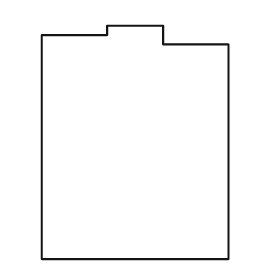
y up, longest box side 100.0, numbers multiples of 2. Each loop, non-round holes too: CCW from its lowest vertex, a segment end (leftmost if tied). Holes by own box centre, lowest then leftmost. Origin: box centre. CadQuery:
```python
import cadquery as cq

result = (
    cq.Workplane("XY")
    .moveTo(-40.0, -50.0)
    .lineTo(40.0, -50.0)
    .lineTo(40.0, 42.0)
    .lineTo(12.0, 42.0)
    .lineTo(12.0, 50.0)
    .lineTo(-12.0, 50.0)
    .lineTo(-12.0, 46.0)
    .lineTo(-40.0, 46.0)
    .close()
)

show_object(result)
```